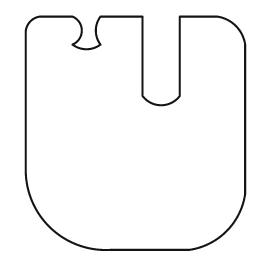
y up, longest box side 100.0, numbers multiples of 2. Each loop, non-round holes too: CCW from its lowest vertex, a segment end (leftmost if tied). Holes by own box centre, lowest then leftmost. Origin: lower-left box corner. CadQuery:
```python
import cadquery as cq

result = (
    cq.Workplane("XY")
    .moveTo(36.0, 0.0)
    .lineTo(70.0, 0.0)
    .threePointArc((86.0, 8.0), (94.0, 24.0))
    .lineTo(94.0, 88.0)
    .threePointArc((90.0, 96.0), (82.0, 100.0))
    .lineTo(66.0, 100.0)
    .lineTo(66.0, 66.0)
    .threePointArc((58.0, 62.0), (50.0, 66.0))
    .lineTo(50.0, 100.0)
    .lineTo(32.0, 100.0)
    .threePointArc((30.0, 94.0), (32.0, 88.0))
    .threePointArc((26.0, 86.0), (20.0, 88.0))
    .threePointArc((24.0, 94.0), (20.0, 100.0))
    .lineTo(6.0, 100.0)
    .threePointArc((2.0, 98.0), (0.0, 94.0))
    .lineTo(0.0, 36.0)
    .threePointArc((10.0, 10.0), (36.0, 0.0))
    .close()
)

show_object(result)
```